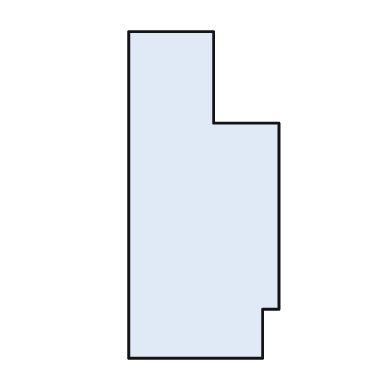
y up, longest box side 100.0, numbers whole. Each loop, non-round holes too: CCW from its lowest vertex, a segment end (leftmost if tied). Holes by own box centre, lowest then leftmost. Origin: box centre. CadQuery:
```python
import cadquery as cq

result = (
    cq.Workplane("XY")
    .moveTo(-23.0, -50.0)
    .lineTo(18.0, -50.0)
    .lineTo(18.0, -35.0)
    .lineTo(23.0, -35.0)
    .lineTo(23.0, 22.0)
    .lineTo(3.0, 22.0)
    .lineTo(3.0, 50.0)
    .lineTo(-23.0, 50.0)
    .close()
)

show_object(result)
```